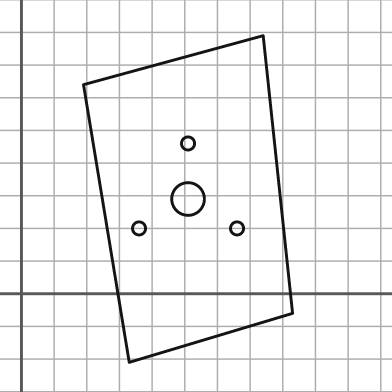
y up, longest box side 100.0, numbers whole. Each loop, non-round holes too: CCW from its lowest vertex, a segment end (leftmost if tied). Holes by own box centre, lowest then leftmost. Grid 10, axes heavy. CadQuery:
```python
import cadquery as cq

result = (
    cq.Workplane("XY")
    .moveTo(33.0, -21.0)
    .lineTo(83.0, -6.0)
    .lineTo(74.0, 79.0)
    .lineTo(19.0, 64.0)
    .close()
    .moveTo(36.0, 20.0)
    .circle(2.0)
    .moveTo(66.0, 20.0)
    .circle(2.0)
    .moveTo(51.0, 29.0)
    .circle(5.0)
    .moveTo(51.0, 46.0)
    .circle(2.0)
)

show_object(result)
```